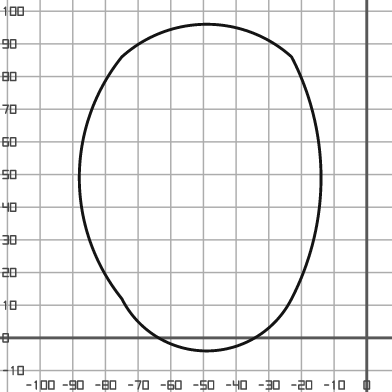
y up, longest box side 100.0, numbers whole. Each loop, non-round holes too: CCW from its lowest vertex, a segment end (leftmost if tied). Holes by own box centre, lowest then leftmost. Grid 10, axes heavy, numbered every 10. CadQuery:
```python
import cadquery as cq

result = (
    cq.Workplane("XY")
    .moveTo(-75.0, 12.0)
    .threePointArc((-49.0, -4.0), (-23.0, 12.0))
    .threePointArc((-14.0, 49.0), (-23.0, 86.0))
    .threePointArc((-49.0, 96.0), (-75.0, 86.0))
    .threePointArc((-88.0, 49.0), (-75.0, 12.0))
    .close()
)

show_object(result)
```